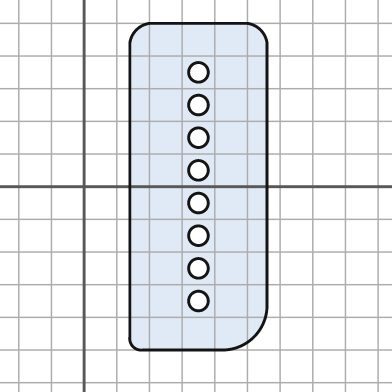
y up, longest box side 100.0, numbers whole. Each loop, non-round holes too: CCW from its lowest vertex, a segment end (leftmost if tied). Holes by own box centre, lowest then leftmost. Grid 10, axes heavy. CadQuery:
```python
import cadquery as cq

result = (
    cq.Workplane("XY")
    .moveTo(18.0, -50.0)
    .lineTo(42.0, -50.0)
    .threePointArc((52.0, -46.0), (56.0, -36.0))
    .lineTo(56.0, 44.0)
    .threePointArc((54.0, 48.0), (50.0, 50.0))
    .lineTo(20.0, 50.0)
    .threePointArc((16.0, 48.0), (14.0, 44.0))
    .lineTo(14.0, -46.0)
    .threePointArc((15.0, -49.0), (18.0, -50.0))
    .close()
    .moveTo(35.0, -35.0)
    .circle(3.0)
    .moveTo(35.0, -25.0)
    .circle(3.0)
    .moveTo(35.0, -15.0)
    .circle(3.0)
    .moveTo(35.0, -5.0)
    .circle(3.0)
    .moveTo(35.0, 5.0)
    .circle(3.0)
    .moveTo(35.0, 15.0)
    .circle(3.0)
    .moveTo(35.0, 25.0)
    .circle(3.0)
    .moveTo(35.0, 35.0)
    .circle(3.0)
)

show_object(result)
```